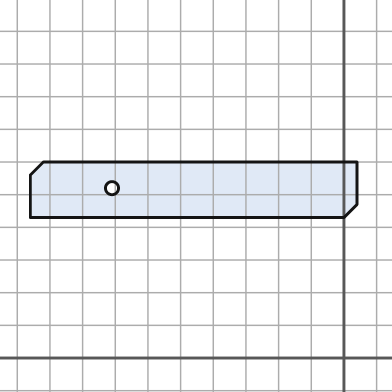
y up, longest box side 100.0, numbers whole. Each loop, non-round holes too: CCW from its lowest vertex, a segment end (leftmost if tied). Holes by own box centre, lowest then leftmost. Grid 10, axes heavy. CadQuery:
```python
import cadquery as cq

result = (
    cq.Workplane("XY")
    .moveTo(-96.0, 43.0)
    .lineTo(0.0, 43.0)
    .lineTo(4.0, 47.0)
    .lineTo(4.0, 60.0)
    .lineTo(-92.0, 60.0)
    .lineTo(-96.0, 56.0)
    .close()
    .moveTo(-71.0, 52.0)
    .circle(2.0)
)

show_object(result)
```